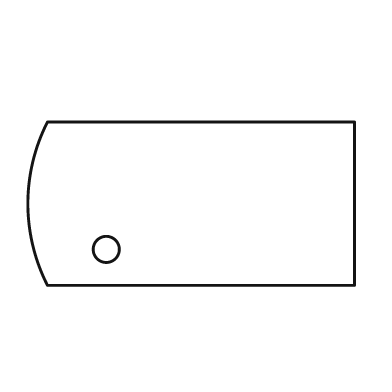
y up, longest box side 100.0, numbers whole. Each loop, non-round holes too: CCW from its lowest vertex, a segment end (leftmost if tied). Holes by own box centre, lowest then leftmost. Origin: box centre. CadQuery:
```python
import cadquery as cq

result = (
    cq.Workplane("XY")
    .moveTo(-44.0, -25.0)
    .lineTo(50.0, -25.0)
    .lineTo(50.0, 25.0)
    .lineTo(-44.0, 25.0)
    .threePointArc((-50.0, 0.0), (-44.0, -25.0))
    .close()
    .moveTo(-26.0, -14.0)
    .circle(4.0)
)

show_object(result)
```